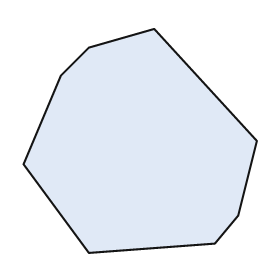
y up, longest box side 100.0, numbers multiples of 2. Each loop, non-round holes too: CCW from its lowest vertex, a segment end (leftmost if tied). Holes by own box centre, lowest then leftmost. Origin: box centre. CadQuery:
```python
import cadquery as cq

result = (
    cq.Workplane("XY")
    .moveTo(-22.0, -48.0)
    .lineTo(32.0, -44.0)
    .lineTo(42.0, -32.0)
    .lineTo(50.0, 0.0)
    .lineTo(6.0, 48.0)
    .lineTo(-22.0, 40.0)
    .lineTo(-34.0, 28.0)
    .lineTo(-50.0, -10.0)
    .close()
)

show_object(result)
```